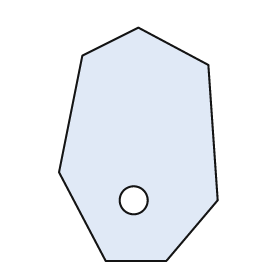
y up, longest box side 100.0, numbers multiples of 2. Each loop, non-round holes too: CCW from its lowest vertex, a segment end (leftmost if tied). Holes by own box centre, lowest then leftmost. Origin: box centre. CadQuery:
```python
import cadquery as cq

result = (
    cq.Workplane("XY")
    .moveTo(-14.0, -50.0)
    .lineTo(12.0, -50.0)
    .lineTo(34.0, -24.0)
    .lineTo(30.0, 34.0)
    .lineTo(0.0, 50.0)
    .lineTo(-24.0, 38.0)
    .lineTo(-34.0, -12.0)
    .close()
    .moveTo(-2.0, -24.0)
    .circle(6.0)
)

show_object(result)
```